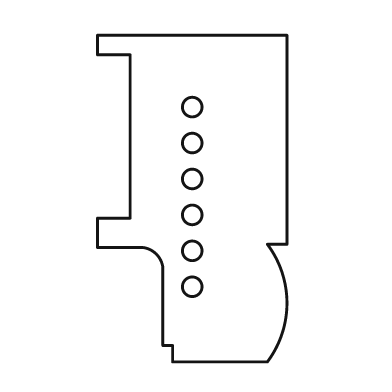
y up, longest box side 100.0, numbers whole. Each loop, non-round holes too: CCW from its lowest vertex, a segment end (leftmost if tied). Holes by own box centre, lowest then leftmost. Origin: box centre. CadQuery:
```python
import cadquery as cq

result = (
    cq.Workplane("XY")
    .moveTo(-6.0, -50.0)
    .lineTo(23.0, -50.0)
    .threePointArc((29.0, -32.0), (23.0, -14.0))
    .lineTo(29.0, -14.0)
    .lineTo(29.0, 50.0)
    .lineTo(-29.0, 50.0)
    .lineTo(-29.0, 44.0)
    .lineTo(-19.0, 44.0)
    .lineTo(-19.0, -6.0)
    .lineTo(-29.0, -6.0)
    .lineTo(-29.0, -15.0)
    .lineTo(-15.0, -15.0)
    .threePointArc((-11.0, -17.0), (-9.0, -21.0))
    .lineTo(-9.0, -45.0)
    .lineTo(-6.0, -45.0)
    .close()
    .moveTo(0.0, -27.0)
    .circle(3.0)
    .moveTo(0.0, -16.0)
    .circle(3.0)
    .moveTo(0.0, -5.0)
    .circle(3.0)
    .moveTo(0.0, 6.0)
    .circle(3.0)
    .moveTo(0.0, 17.0)
    .circle(3.0)
    .moveTo(0.0, 28.0)
    .circle(3.0)
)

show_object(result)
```